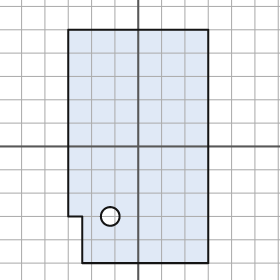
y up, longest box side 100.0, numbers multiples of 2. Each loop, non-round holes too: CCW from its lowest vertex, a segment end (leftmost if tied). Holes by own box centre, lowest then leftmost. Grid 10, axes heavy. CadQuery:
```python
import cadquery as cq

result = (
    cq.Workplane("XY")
    .moveTo(-24.0, -50.0)
    .lineTo(30.0, -50.0)
    .lineTo(30.0, 50.0)
    .lineTo(-30.0, 50.0)
    .lineTo(-30.0, -30.0)
    .lineTo(-24.0, -30.0)
    .close()
    .moveTo(-12.0, -30.0)
    .circle(4.0)
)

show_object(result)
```